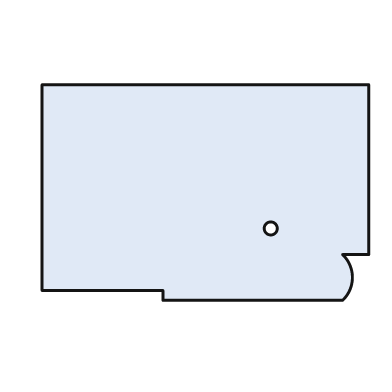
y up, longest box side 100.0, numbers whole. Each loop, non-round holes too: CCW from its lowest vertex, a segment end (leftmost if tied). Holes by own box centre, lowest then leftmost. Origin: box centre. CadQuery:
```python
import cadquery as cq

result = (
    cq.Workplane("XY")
    .moveTo(-13.0, -33.0)
    .lineTo(42.0, -33.0)
    .threePointArc((45.0, -26.0), (42.0, -19.0))
    .lineTo(50.0, -19.0)
    .lineTo(50.0, 33.0)
    .lineTo(-50.0, 33.0)
    .lineTo(-50.0, -30.0)
    .lineTo(-13.0, -30.0)
    .close()
    .moveTo(20.0, -11.0)
    .circle(2.0)
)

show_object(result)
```